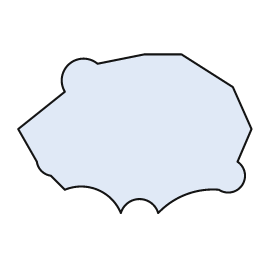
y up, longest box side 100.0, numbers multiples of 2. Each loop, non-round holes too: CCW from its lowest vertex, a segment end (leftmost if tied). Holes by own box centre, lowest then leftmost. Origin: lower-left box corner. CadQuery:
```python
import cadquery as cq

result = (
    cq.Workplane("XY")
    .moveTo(44.0, 0.0)
    .threePointArc((52.0, 6.0), (60.0, 0.0))
    .threePointArc((72.0, 8.0), (86.0, 10.0))
    .threePointArc((96.0, 12.0), (94.0, 22.0))
    .lineTo(100.0, 36.0)
    .lineTo(92.0, 54.0)
    .lineTo(70.0, 68.0)
    .lineTo(54.0, 68.0)
    .lineTo(34.0, 64.0)
    .threePointArc((22.0, 64.0), (20.0, 52.0))
    .lineTo(0.0, 36.0)
    .lineTo(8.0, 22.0)
    .threePointArc((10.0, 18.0), (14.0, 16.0))
    .lineTo(20.0, 10.0)
    .threePointArc((34.0, 10.0), (44.0, 0.0))
    .close()
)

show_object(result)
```